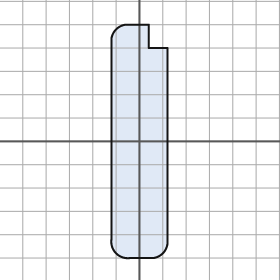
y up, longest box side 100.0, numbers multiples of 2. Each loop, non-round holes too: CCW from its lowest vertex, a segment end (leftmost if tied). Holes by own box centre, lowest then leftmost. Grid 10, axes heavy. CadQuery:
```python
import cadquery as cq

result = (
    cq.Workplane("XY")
    .moveTo(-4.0, -50.0)
    .lineTo(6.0, -50.0)
    .threePointArc((10.0, -48.0), (12.0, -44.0))
    .lineTo(12.0, 40.0)
    .lineTo(4.0, 40.0)
    .lineTo(4.0, 50.0)
    .lineTo(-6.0, 50.0)
    .threePointArc((-10.0, 48.0), (-12.0, 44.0))
    .lineTo(-12.0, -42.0)
    .threePointArc((-10.0, -48.0), (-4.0, -50.0))
    .close()
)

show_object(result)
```